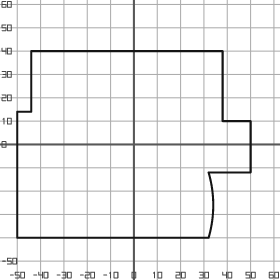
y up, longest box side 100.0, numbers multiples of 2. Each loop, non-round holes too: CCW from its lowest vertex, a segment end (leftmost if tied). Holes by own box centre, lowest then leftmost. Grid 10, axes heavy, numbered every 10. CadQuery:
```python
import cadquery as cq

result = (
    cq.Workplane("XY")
    .moveTo(-50.0, -40.0)
    .lineTo(32.0, -40.0)
    .threePointArc((34.0, -26.0), (32.0, -12.0))
    .lineTo(50.0, -12.0)
    .lineTo(50.0, 10.0)
    .lineTo(38.0, 10.0)
    .lineTo(38.0, 40.0)
    .lineTo(-44.0, 40.0)
    .lineTo(-44.0, 14.0)
    .lineTo(-50.0, 14.0)
    .close()
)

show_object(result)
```